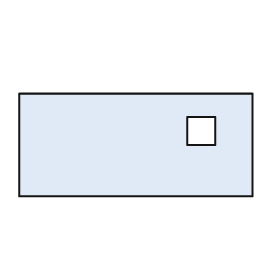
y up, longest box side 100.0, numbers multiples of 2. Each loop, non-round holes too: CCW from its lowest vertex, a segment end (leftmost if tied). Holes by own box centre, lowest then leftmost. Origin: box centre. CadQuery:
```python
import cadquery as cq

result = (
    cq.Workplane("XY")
    .moveTo(-50.0, -22.0)
    .lineTo(50.0, -22.0)
    .lineTo(50.0, 22.0)
    .lineTo(-50.0, 22.0)
    .close()
    .moveTo(22.0, 0.0)
    .lineTo(34.0, 0.0)
    .lineTo(34.0, 12.0)
    .lineTo(22.0, 12.0)
    .close()
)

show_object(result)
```